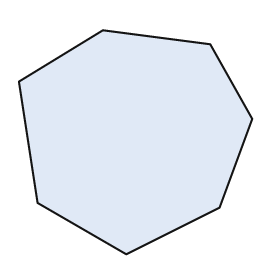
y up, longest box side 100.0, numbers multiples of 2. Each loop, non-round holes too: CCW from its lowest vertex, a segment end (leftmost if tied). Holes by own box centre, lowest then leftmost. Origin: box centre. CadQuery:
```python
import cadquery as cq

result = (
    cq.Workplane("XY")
    .moveTo(-4.0, -48.0)
    .lineTo(36.0, -28.0)
    .lineTo(50.0, 10.0)
    .lineTo(32.0, 42.0)
    .lineTo(-14.0, 48.0)
    .lineTo(-50.0, 26.0)
    .lineTo(-42.0, -26.0)
    .close()
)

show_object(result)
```